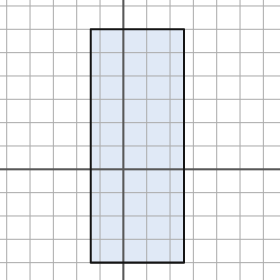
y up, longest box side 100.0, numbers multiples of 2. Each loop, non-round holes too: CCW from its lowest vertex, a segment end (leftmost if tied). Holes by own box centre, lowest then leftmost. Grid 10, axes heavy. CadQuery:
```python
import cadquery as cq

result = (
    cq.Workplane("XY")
    .moveTo(-14.0, -40.0)
    .lineTo(26.0, -40.0)
    .lineTo(26.0, 60.0)
    .lineTo(-14.0, 60.0)
    .close()
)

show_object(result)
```